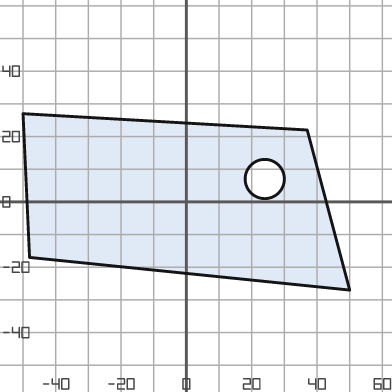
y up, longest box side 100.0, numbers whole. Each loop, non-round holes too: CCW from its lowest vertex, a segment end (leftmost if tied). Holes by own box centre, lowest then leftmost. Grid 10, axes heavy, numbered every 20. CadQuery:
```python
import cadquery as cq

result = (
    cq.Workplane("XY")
    .moveTo(50.0, -27.0)
    .lineTo(37.0, 22.0)
    .lineTo(-50.0, 27.0)
    .lineTo(-48.0, -17.0)
    .close()
    .moveTo(24.0, 7.0)
    .circle(6.0)
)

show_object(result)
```